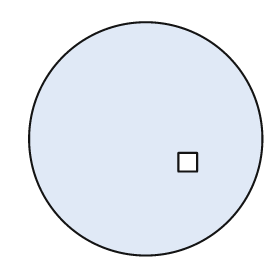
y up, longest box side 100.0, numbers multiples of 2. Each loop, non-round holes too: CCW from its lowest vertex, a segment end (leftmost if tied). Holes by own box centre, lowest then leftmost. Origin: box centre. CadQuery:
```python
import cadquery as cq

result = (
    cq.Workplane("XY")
    .moveTo(0.0, 0.0)
    .circle(50.0)
    .moveTo(14.0, -14.0)
    .lineTo(22.0, -14.0)
    .lineTo(22.0, -6.0)
    .lineTo(14.0, -6.0)
    .close()
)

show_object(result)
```